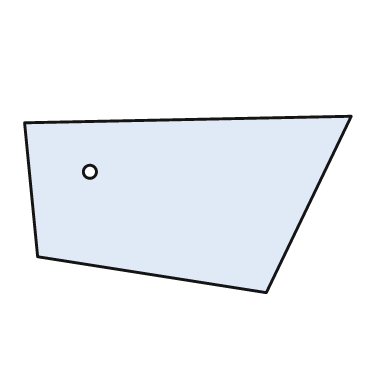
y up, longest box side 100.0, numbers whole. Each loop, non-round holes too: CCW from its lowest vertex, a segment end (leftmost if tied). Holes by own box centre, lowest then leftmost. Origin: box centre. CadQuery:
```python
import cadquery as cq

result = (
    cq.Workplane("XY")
    .moveTo(24.0, -27.0)
    .lineTo(50.0, 27.0)
    .lineTo(-50.0, 25.0)
    .lineTo(-46.0, -16.0)
    .close()
    .moveTo(-30.0, 10.0)
    .circle(2.0)
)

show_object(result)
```